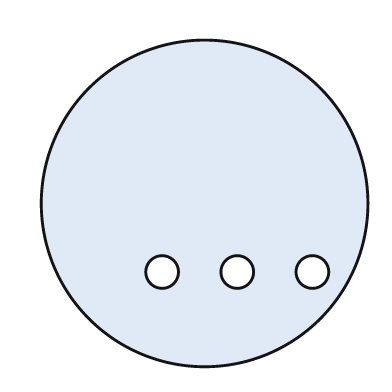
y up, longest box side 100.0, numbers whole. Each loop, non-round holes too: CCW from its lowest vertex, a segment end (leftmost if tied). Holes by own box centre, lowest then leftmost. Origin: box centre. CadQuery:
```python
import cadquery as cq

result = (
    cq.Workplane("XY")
    .moveTo(0.0, 0.0)
    .circle(50.0)
    .moveTo(-13.0, -21.0)
    .circle(5.0)
    .moveTo(10.0, -21.0)
    .circle(5.0)
    .moveTo(33.0, -21.0)
    .circle(5.0)
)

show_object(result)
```